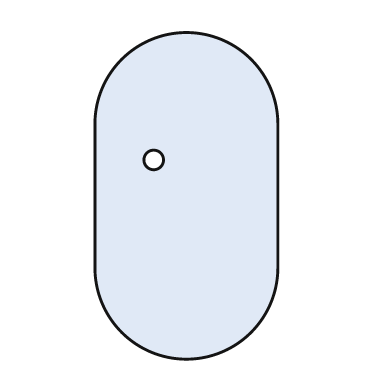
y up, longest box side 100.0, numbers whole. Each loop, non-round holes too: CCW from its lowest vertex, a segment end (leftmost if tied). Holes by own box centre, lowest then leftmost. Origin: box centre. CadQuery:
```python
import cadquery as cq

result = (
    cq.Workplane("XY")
    .moveTo(-28.0, -22.0)
    .threePointArc((0.0, -50.0), (28.0, -22.0))
    .lineTo(28.0, 22.0)
    .threePointArc((0.0, 50.0), (-28.0, 22.0))
    .close()
    .moveTo(-10.0, 11.0)
    .circle(3.0)
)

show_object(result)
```